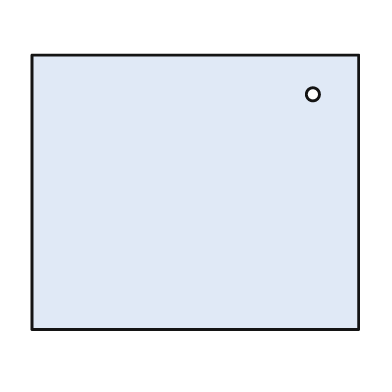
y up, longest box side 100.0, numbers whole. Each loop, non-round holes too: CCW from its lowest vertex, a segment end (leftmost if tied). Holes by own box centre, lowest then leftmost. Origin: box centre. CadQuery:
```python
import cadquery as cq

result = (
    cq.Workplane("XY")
    .moveTo(-50.0, -42.0)
    .lineTo(50.0, -42.0)
    .lineTo(50.0, 42.0)
    .lineTo(-50.0, 42.0)
    .close()
    .moveTo(36.0, 30.0)
    .circle(2.0)
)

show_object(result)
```